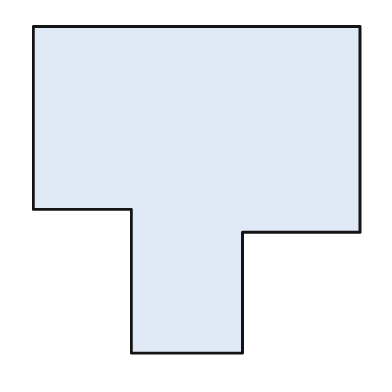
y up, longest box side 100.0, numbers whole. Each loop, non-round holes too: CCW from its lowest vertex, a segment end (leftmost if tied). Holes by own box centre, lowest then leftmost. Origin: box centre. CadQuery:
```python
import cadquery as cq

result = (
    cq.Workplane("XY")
    .moveTo(-20.0, -50.0)
    .lineTo(14.0, -50.0)
    .lineTo(14.0, -13.0)
    .lineTo(50.0, -13.0)
    .lineTo(50.0, 50.0)
    .lineTo(-50.0, 50.0)
    .lineTo(-50.0, -6.0)
    .lineTo(-20.0, -6.0)
    .close()
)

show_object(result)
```